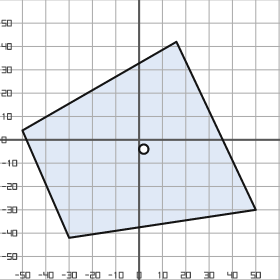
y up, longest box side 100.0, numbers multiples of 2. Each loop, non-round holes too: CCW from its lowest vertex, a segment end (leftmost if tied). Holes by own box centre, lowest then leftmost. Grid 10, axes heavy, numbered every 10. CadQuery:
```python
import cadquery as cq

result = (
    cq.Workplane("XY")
    .moveTo(-30.0, -42.0)
    .lineTo(50.0, -30.0)
    .lineTo(16.0, 42.0)
    .lineTo(-50.0, 4.0)
    .close()
    .moveTo(2.0, -4.0)
    .circle(2.0)
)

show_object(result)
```